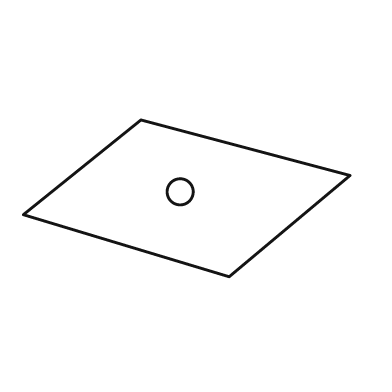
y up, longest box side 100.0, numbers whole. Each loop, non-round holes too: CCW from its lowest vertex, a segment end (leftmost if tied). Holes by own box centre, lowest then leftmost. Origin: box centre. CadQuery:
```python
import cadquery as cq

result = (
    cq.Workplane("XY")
    .moveTo(13.0, -24.0)
    .lineTo(50.0, 7.0)
    .lineTo(-14.0, 24.0)
    .lineTo(-50.0, -5.0)
    .close()
    .moveTo(-2.0, 2.0)
    .circle(4.0)
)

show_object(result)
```